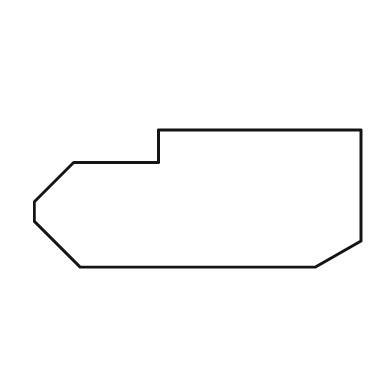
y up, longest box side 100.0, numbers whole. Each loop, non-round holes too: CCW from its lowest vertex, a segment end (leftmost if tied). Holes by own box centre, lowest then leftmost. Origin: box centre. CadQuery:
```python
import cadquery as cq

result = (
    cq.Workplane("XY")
    .moveTo(-36.0, -21.0)
    .lineTo(36.0, -21.0)
    .lineTo(50.0, -13.0)
    .lineTo(50.0, 21.0)
    .lineTo(-12.0, 21.0)
    .lineTo(-12.0, 11.0)
    .lineTo(-38.0, 11.0)
    .lineTo(-50.0, -1.0)
    .lineTo(-50.0, -7.0)
    .close()
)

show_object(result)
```